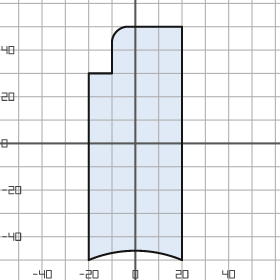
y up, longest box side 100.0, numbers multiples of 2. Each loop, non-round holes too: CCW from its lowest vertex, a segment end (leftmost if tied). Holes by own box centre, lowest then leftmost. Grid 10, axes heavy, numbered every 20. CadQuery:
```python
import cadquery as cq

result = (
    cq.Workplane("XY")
    .moveTo(-20.0, -50.0)
    .threePointArc((0.0, -46.0), (20.0, -50.0))
    .lineTo(20.0, 50.0)
    .lineTo(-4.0, 50.0)
    .threePointArc((-8.0, 48.0), (-10.0, 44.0))
    .lineTo(-10.0, 30.0)
    .lineTo(-20.0, 30.0)
    .close()
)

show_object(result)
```